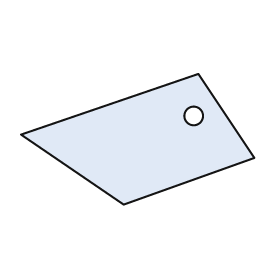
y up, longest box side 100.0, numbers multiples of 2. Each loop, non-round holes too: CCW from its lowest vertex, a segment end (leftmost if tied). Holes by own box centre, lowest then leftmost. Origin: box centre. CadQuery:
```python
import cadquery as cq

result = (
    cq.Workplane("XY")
    .moveTo(-6.0, -28.0)
    .lineTo(50.0, -8.0)
    .lineTo(26.0, 28.0)
    .lineTo(-50.0, 2.0)
    .close()
    .moveTo(24.0, 10.0)
    .circle(4.0)
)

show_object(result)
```